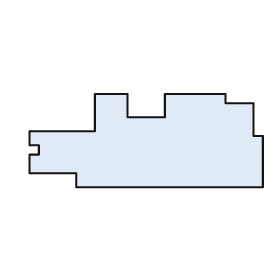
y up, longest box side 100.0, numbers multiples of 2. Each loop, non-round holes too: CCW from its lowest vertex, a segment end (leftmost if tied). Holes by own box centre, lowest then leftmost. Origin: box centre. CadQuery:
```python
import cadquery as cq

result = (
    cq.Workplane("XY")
    .moveTo(-30.0, -20.0)
    .lineTo(50.0, -20.0)
    .lineTo(50.0, 2.0)
    .lineTo(46.0, 2.0)
    .lineTo(46.0, 16.0)
    .lineTo(34.0, 16.0)
    .lineTo(34.0, 20.0)
    .lineTo(8.0, 20.0)
    .lineTo(8.0, 10.0)
    .lineTo(-8.0, 10.0)
    .lineTo(-8.0, 20.0)
    .lineTo(-22.0, 20.0)
    .lineTo(-22.0, 4.0)
    .lineTo(-50.0, 4.0)
    .lineTo(-50.0, -2.0)
    .lineTo(-46.0, -2.0)
    .lineTo(-46.0, -6.0)
    .lineTo(-50.0, -6.0)
    .lineTo(-50.0, -14.0)
    .lineTo(-30.0, -14.0)
    .close()
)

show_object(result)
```